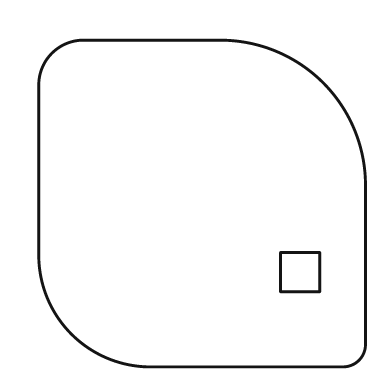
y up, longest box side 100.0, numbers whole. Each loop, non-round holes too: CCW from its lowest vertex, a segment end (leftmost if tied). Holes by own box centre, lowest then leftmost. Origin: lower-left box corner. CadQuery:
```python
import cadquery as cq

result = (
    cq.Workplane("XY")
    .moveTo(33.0, 0.0)
    .lineTo(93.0, 0.0)
    .threePointArc((98.0, 2.0), (100.0, 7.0))
    .lineTo(100.0, 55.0)
    .threePointArc((87.0, 87.0), (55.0, 100.0))
    .lineTo(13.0, 100.0)
    .threePointArc((4.0, 96.0), (0.0, 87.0))
    .lineTo(0.0, 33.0)
    .threePointArc((10.0, 10.0), (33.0, 0.0))
    .close()
    .moveTo(74.0, 23.0)
    .lineTo(86.0, 23.0)
    .lineTo(86.0, 35.0)
    .lineTo(74.0, 35.0)
    .close()
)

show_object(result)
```